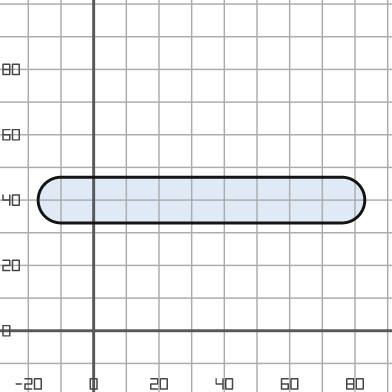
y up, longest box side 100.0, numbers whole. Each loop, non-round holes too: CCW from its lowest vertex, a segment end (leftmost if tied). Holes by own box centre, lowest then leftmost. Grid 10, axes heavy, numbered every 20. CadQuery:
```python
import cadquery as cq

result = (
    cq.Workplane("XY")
    .moveTo(-10.0, 33.0)
    .lineTo(76.0, 33.0)
    .threePointArc((83.0, 40.0), (76.0, 47.0))
    .lineTo(-10.0, 47.0)
    .threePointArc((-17.0, 40.0), (-10.0, 33.0))
    .close()
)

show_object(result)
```